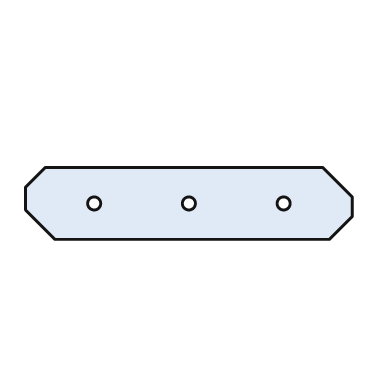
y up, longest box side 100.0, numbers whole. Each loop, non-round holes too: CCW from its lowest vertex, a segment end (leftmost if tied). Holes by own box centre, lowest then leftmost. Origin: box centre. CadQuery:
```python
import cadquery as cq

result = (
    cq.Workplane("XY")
    .moveTo(-41.0, -11.0)
    .lineTo(43.0, -11.0)
    .lineTo(50.0, -4.0)
    .lineTo(50.0, 2.0)
    .lineTo(41.0, 11.0)
    .lineTo(-44.0, 11.0)
    .lineTo(-50.0, 5.0)
    .lineTo(-50.0, -2.0)
    .close()
    .moveTo(-29.0, 0.0)
    .circle(2.0)
    .moveTo(0.0, 0.0)
    .circle(2.0)
    .moveTo(29.0, 0.0)
    .circle(2.0)
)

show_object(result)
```